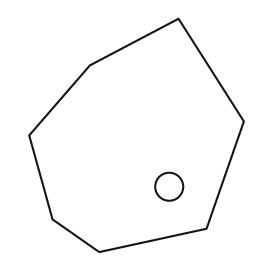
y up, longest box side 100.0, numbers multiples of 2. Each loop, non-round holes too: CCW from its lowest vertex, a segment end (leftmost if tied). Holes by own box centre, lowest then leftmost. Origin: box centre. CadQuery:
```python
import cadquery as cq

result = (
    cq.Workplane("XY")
    .moveTo(-16.0, -50.0)
    .lineTo(30.0, -40.0)
    .lineTo(46.0, 6.0)
    .lineTo(18.0, 50.0)
    .lineTo(-20.0, 30.0)
    .lineTo(-46.0, 0.0)
    .lineTo(-36.0, -36.0)
    .close()
    .moveTo(14.0, -22.0)
    .circle(6.0)
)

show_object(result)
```